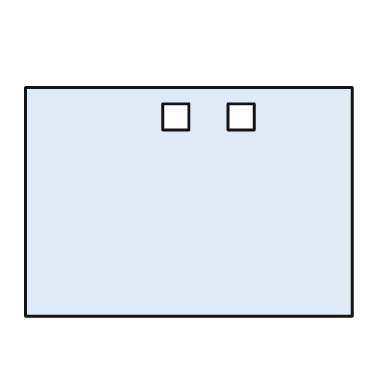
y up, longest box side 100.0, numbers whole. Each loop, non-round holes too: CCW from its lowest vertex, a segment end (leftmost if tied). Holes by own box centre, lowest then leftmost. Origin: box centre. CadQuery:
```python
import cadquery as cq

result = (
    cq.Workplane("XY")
    .moveTo(-50.0, -35.0)
    .lineTo(50.0, -35.0)
    .lineTo(50.0, 35.0)
    .lineTo(-50.0, 35.0)
    .close()
    .moveTo(-8.0, 22.0)
    .lineTo(0.0, 22.0)
    .lineTo(0.0, 30.0)
    .lineTo(-8.0, 30.0)
    .close()
    .moveTo(12.0, 22.0)
    .lineTo(20.0, 22.0)
    .lineTo(20.0, 30.0)
    .lineTo(12.0, 30.0)
    .close()
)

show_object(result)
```